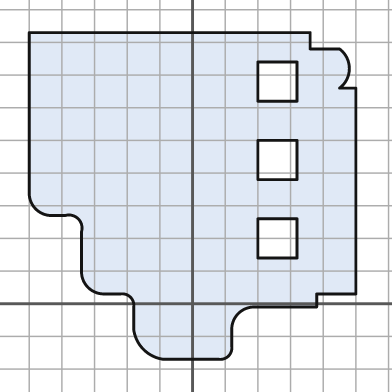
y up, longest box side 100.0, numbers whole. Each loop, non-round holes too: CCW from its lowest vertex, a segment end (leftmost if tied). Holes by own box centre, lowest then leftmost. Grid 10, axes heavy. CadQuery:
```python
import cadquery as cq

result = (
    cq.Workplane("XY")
    .moveTo(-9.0, -17.0)
    .lineTo(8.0, -17.0)
    .threePointArc((11.0, -16.0), (12.0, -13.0))
    .lineTo(12.0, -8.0)
    .threePointArc((14.0, -3.0), (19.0, -1.0))
    .lineTo(38.0, -1.0)
    .lineTo(38.0, 3.0)
    .lineTo(50.0, 3.0)
    .lineTo(50.0, 66.0)
    .lineTo(45.0, 66.0)
    .threePointArc((48.0, 72.0), (45.0, 78.0))
    .lineTo(36.0, 78.0)
    .lineTo(36.0, 83.0)
    .lineTo(-50.0, 83.0)
    .lineTo(-50.0, 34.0)
    .threePointArc((-48.0, 29.0), (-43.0, 27.0))
    .lineTo(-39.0, 27.0)
    .threePointArc((-35.0, 26.0), (-34.0, 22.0))
    .lineTo(-34.0, 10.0)
    .threePointArc((-32.0, 5.0), (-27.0, 3.0))
    .lineTo(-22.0, 3.0)
    .threePointArc((-19.0, 2.0), (-18.0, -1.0))
    .lineTo(-18.0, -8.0)
    .threePointArc((-15.0, -14.0), (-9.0, -17.0))
    .close()
    .moveTo(20.0, 14.0)
    .lineTo(32.0, 14.0)
    .lineTo(32.0, 26.0)
    .lineTo(20.0, 26.0)
    .close()
    .moveTo(20.0, 38.0)
    .lineTo(32.0, 38.0)
    .lineTo(32.0, 50.0)
    .lineTo(20.0, 50.0)
    .close()
    .moveTo(20.0, 62.0)
    .lineTo(32.0, 62.0)
    .lineTo(32.0, 74.0)
    .lineTo(20.0, 74.0)
    .close()
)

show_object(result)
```